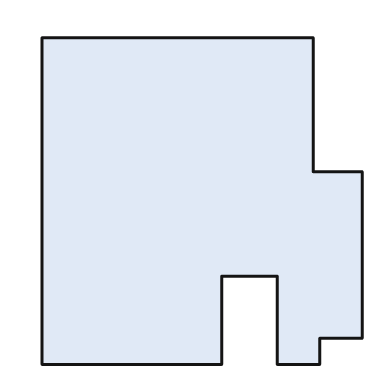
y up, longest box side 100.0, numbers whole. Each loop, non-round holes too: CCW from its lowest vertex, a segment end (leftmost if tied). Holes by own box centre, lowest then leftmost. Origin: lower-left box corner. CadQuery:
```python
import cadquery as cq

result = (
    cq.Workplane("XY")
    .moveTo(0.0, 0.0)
    .lineTo(55.0, 0.0)
    .lineTo(55.0, 27.0)
    .lineTo(72.0, 27.0)
    .lineTo(72.0, 0.0)
    .lineTo(85.0, 0.0)
    .lineTo(85.0, 8.0)
    .lineTo(98.0, 8.0)
    .lineTo(98.0, 59.0)
    .lineTo(83.0, 59.0)
    .lineTo(83.0, 100.0)
    .lineTo(0.0, 100.0)
    .close()
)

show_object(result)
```